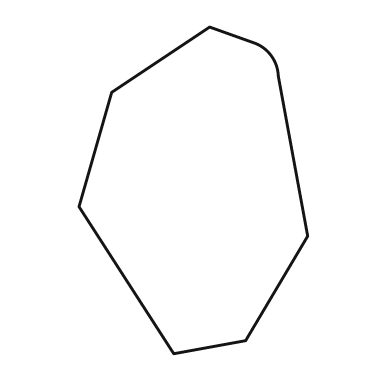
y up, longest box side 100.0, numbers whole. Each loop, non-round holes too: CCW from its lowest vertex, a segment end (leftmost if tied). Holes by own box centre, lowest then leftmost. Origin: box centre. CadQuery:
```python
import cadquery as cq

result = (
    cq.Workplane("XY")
    .moveTo(-6.0, -50.0)
    .lineTo(16.0, -46.0)
    .lineTo(35.0, -14.0)
    .lineTo(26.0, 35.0)
    .threePointArc((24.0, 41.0), (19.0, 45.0))
    .lineTo(5.0, 50.0)
    .lineTo(-25.0, 30.0)
    .lineTo(-35.0, -5.0)
    .close()
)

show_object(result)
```